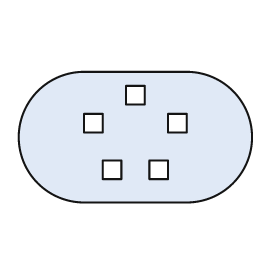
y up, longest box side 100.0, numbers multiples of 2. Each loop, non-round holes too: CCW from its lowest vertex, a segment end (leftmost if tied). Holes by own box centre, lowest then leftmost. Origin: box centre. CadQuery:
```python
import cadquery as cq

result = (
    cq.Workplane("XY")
    .moveTo(-22.0, -28.0)
    .lineTo(22.0, -28.0)
    .threePointArc((50.0, 0.0), (22.0, 28.0))
    .lineTo(-22.0, 28.0)
    .threePointArc((-50.0, 0.0), (-22.0, -28.0))
    .close()
    .moveTo(-14.0, -18.0)
    .lineTo(-6.0, -18.0)
    .lineTo(-6.0, -10.0)
    .lineTo(-14.0, -10.0)
    .close()
    .moveTo(6.0, -18.0)
    .lineTo(14.0, -18.0)
    .lineTo(14.0, -10.0)
    .lineTo(6.0, -10.0)
    .close()
    .moveTo(-22.0, 2.0)
    .lineTo(-14.0, 2.0)
    .lineTo(-14.0, 10.0)
    .lineTo(-22.0, 10.0)
    .close()
    .moveTo(14.0, 2.0)
    .lineTo(22.0, 2.0)
    .lineTo(22.0, 10.0)
    .lineTo(14.0, 10.0)
    .close()
    .moveTo(-4.0, 14.0)
    .lineTo(4.0, 14.0)
    .lineTo(4.0, 22.0)
    .lineTo(-4.0, 22.0)
    .close()
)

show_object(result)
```